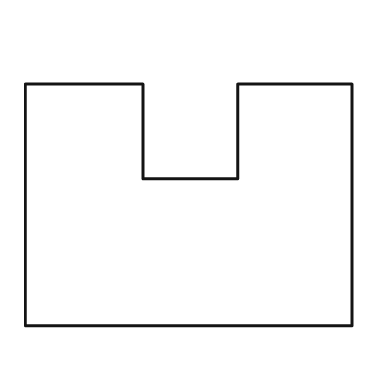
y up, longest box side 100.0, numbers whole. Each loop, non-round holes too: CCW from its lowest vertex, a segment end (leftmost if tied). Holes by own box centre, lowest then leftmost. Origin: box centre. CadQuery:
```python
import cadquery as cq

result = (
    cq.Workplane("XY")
    .moveTo(-50.0, -37.0)
    .lineTo(50.0, -37.0)
    .lineTo(50.0, 37.0)
    .lineTo(15.0, 37.0)
    .lineTo(15.0, 8.0)
    .lineTo(-14.0, 8.0)
    .lineTo(-14.0, 37.0)
    .lineTo(-50.0, 37.0)
    .close()
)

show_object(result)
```